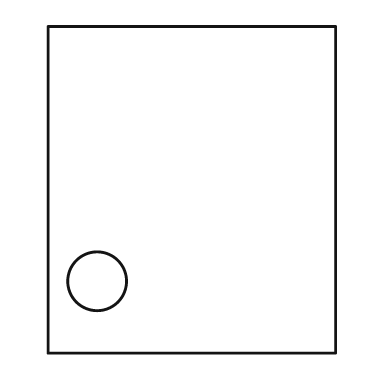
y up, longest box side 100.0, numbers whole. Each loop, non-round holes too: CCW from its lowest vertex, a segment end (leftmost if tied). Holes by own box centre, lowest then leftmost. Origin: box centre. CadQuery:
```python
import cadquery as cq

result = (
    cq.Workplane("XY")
    .moveTo(-44.0, -50.0)
    .lineTo(44.0, -50.0)
    .lineTo(44.0, 50.0)
    .lineTo(-44.0, 50.0)
    .close()
    .moveTo(-29.0, -28.0)
    .circle(9.0)
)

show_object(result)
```